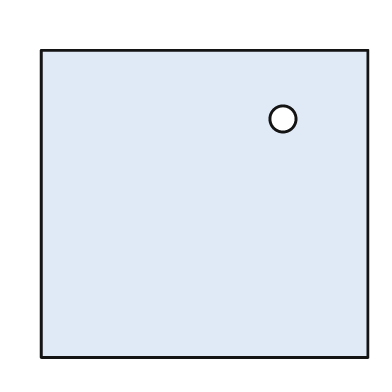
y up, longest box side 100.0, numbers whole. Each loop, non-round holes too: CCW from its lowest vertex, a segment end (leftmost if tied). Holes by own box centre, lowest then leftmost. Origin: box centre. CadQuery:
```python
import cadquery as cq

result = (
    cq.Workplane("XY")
    .moveTo(-50.0, -47.0)
    .lineTo(50.0, -47.0)
    .lineTo(50.0, 47.0)
    .lineTo(-50.0, 47.0)
    .close()
    .moveTo(24.0, 26.0)
    .circle(4.0)
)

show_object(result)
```